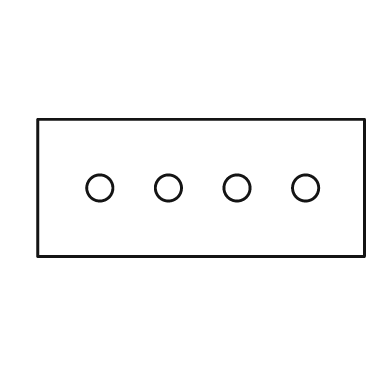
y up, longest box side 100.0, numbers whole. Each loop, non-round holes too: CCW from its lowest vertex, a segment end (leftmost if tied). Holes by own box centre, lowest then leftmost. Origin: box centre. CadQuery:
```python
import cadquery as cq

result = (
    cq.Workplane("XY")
    .moveTo(-50.0, -21.0)
    .lineTo(50.0, -21.0)
    .lineTo(50.0, 21.0)
    .lineTo(-50.0, 21.0)
    .close()
    .moveTo(-31.0, 0.0)
    .circle(4.0)
    .moveTo(-10.0, 0.0)
    .circle(4.0)
    .moveTo(11.0, 0.0)
    .circle(4.0)
    .moveTo(32.0, 0.0)
    .circle(4.0)
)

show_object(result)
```